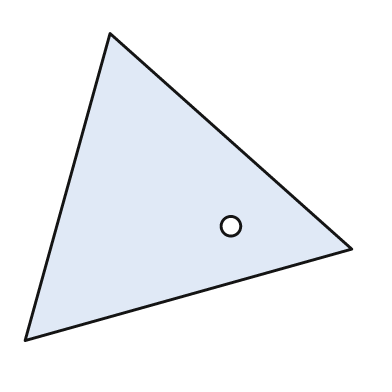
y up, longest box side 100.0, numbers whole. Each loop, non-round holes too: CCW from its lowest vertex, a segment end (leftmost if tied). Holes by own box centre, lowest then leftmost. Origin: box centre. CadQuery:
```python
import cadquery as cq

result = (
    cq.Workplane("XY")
    .moveTo(-50.0, -47.0)
    .lineTo(50.0, -19.0)
    .lineTo(-24.0, 47.0)
    .close()
    .moveTo(13.0, -12.0)
    .circle(3.0)
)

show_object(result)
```